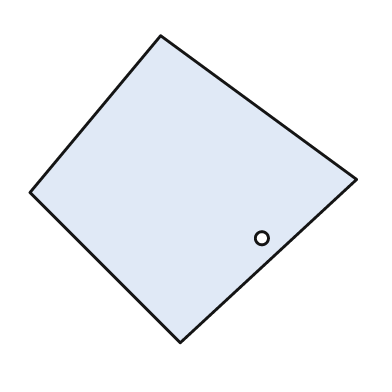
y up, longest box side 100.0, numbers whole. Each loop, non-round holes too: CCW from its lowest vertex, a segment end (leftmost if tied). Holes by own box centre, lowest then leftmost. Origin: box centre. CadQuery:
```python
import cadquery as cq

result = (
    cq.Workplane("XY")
    .moveTo(-4.0, -47.0)
    .lineTo(50.0, 3.0)
    .lineTo(-10.0, 47.0)
    .lineTo(-50.0, -1.0)
    .close()
    .moveTo(21.0, -15.0)
    .circle(2.0)
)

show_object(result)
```